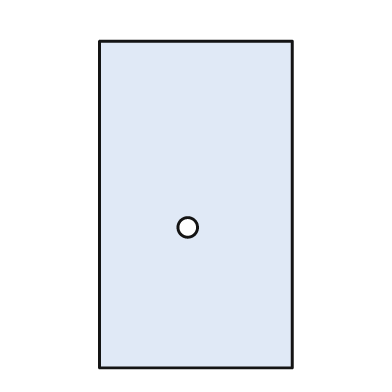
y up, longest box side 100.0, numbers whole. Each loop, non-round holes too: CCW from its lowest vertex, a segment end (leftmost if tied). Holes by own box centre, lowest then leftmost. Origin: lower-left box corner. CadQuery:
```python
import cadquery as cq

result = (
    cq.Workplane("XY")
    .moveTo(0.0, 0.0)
    .lineTo(59.0, 0.0)
    .lineTo(59.0, 100.0)
    .lineTo(0.0, 100.0)
    .close()
    .moveTo(27.0, 43.0)
    .circle(3.0)
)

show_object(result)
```